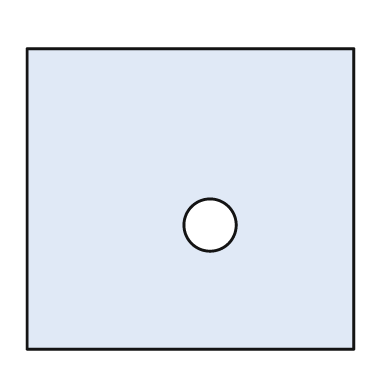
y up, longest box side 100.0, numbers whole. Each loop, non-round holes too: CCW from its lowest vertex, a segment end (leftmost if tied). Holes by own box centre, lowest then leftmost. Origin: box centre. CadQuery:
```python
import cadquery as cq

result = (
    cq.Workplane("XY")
    .moveTo(-50.0, -46.0)
    .lineTo(50.0, -46.0)
    .lineTo(50.0, 46.0)
    .lineTo(-50.0, 46.0)
    .close()
    .moveTo(6.0, -8.0)
    .circle(8.0)
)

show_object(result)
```